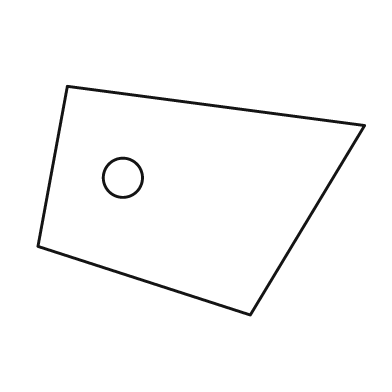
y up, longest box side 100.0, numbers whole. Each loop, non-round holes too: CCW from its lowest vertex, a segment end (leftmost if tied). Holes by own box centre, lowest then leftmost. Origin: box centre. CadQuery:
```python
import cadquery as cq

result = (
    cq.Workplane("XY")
    .moveTo(15.0, -35.0)
    .lineTo(50.0, 23.0)
    .lineTo(-41.0, 35.0)
    .lineTo(-50.0, -14.0)
    .close()
    .moveTo(-24.0, 7.0)
    .circle(6.0)
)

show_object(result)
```